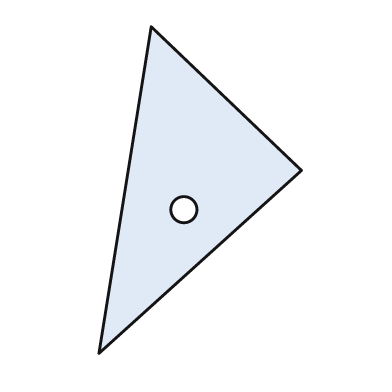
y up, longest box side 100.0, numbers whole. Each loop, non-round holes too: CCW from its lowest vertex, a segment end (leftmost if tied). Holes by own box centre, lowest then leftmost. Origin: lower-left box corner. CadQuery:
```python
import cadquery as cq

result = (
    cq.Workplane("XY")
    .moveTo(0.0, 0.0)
    .lineTo(62.0, 56.0)
    .lineTo(16.0, 100.0)
    .close()
    .moveTo(26.0, 44.0)
    .circle(4.0)
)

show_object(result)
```